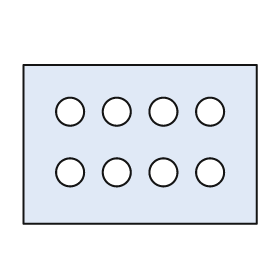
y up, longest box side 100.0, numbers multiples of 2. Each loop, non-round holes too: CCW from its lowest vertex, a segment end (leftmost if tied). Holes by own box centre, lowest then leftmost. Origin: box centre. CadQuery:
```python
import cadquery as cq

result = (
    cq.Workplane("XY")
    .moveTo(-50.0, -34.0)
    .lineTo(50.0, -34.0)
    .lineTo(50.0, 34.0)
    .lineTo(-50.0, 34.0)
    .close()
    .moveTo(-30.0, -12.0)
    .circle(6.0)
    .moveTo(-10.0, -12.0)
    .circle(6.0)
    .moveTo(10.0, -12.0)
    .circle(6.0)
    .moveTo(30.0, -12.0)
    .circle(6.0)
    .moveTo(-30.0, 14.0)
    .circle(6.0)
    .moveTo(-10.0, 14.0)
    .circle(6.0)
    .moveTo(10.0, 14.0)
    .circle(6.0)
    .moveTo(30.0, 14.0)
    .circle(6.0)
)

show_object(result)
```